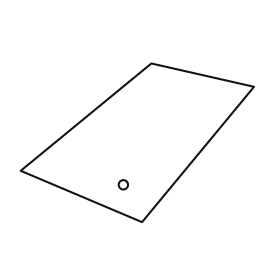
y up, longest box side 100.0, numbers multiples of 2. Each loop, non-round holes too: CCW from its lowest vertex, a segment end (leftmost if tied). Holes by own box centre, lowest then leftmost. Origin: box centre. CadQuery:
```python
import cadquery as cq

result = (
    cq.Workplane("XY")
    .moveTo(2.0, -34.0)
    .lineTo(50.0, 24.0)
    .lineTo(6.0, 34.0)
    .lineTo(-50.0, -12.0)
    .close()
    .moveTo(-6.0, -18.0)
    .circle(2.0)
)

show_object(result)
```